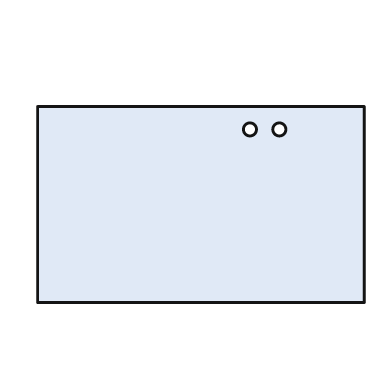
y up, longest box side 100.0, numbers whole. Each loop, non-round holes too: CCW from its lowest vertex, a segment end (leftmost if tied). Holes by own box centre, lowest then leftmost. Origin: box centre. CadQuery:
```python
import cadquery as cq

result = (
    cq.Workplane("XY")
    .moveTo(-50.0, -30.0)
    .lineTo(50.0, -30.0)
    .lineTo(50.0, 30.0)
    .lineTo(-50.0, 30.0)
    .close()
    .moveTo(15.0, 23.0)
    .circle(2.0)
    .moveTo(24.0, 23.0)
    .circle(2.0)
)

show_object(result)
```